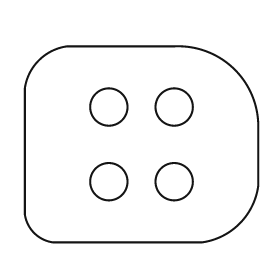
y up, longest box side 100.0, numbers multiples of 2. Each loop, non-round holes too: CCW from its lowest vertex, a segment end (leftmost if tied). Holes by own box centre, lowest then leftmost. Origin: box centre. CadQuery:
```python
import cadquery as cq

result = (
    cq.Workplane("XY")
    .moveTo(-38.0, -42.0)
    .lineTo(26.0, -42.0)
    .threePointArc((42.0, -34.0), (50.0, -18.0))
    .lineTo(50.0, 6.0)
    .threePointArc((40.0, 32.0), (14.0, 42.0))
    .lineTo(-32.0, 42.0)
    .threePointArc((-44.0, 36.0), (-50.0, 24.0))
    .lineTo(-50.0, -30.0)
    .threePointArc((-46.0, -38.0), (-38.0, -42.0))
    .close()
    .moveTo(-14.0, -16.0)
    .circle(8.0)
    .moveTo(14.0, -16.0)
    .circle(8.0)
    .moveTo(-14.0, 16.0)
    .circle(8.0)
    .moveTo(14.0, 16.0)
    .circle(8.0)
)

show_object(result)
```